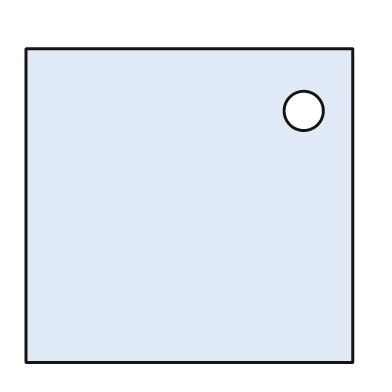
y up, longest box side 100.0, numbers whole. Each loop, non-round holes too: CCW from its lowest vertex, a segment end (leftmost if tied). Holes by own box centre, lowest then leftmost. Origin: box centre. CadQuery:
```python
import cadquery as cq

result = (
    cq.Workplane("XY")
    .moveTo(-50.0, -48.0)
    .lineTo(50.0, -48.0)
    .lineTo(50.0, 48.0)
    .lineTo(-50.0, 48.0)
    .close()
    .moveTo(35.0, 29.0)
    .circle(6.0)
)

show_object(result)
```